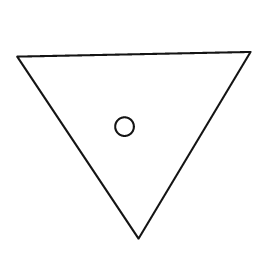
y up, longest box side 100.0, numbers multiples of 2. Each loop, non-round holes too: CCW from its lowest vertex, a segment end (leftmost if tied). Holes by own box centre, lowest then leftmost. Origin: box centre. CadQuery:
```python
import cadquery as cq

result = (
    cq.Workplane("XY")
    .moveTo(2.0, -40.0)
    .lineTo(50.0, 40.0)
    .lineTo(-50.0, 38.0)
    .close()
    .moveTo(-4.0, 8.0)
    .circle(4.0)
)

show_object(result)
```